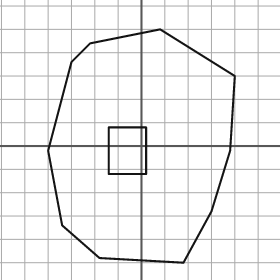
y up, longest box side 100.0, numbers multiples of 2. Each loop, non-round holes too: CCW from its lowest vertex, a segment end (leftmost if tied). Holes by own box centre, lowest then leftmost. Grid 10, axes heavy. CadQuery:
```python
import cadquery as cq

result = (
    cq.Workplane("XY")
    .moveTo(18.0, -50.0)
    .lineTo(30.0, -28.0)
    .lineTo(38.0, -2.0)
    .lineTo(40.0, 30.0)
    .lineTo(8.0, 50.0)
    .lineTo(-22.0, 44.0)
    .lineTo(-30.0, 36.0)
    .lineTo(-40.0, -2.0)
    .lineTo(-34.0, -34.0)
    .lineTo(-18.0, -48.0)
    .close()
    .moveTo(-14.0, -12.0)
    .lineTo(2.0, -12.0)
    .lineTo(2.0, 8.0)
    .lineTo(-14.0, 8.0)
    .close()
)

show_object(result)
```